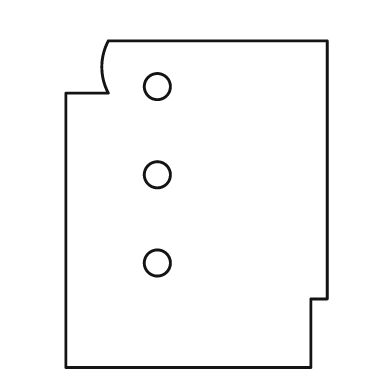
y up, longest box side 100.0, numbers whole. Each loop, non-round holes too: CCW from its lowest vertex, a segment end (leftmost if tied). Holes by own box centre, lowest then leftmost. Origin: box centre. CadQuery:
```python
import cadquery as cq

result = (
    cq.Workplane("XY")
    .moveTo(-40.0, -50.0)
    .lineTo(35.0, -50.0)
    .lineTo(35.0, -29.0)
    .lineTo(40.0, -29.0)
    .lineTo(40.0, 50.0)
    .lineTo(-27.0, 50.0)
    .threePointArc((-29.0, 42.0), (-27.0, 34.0))
    .lineTo(-40.0, 34.0)
    .close()
    .moveTo(-12.0, -18.0)
    .circle(4.0)
    .moveTo(-12.0, 9.0)
    .circle(4.0)
    .moveTo(-12.0, 36.0)
    .circle(4.0)
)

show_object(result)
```